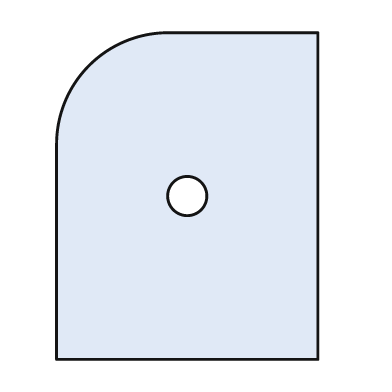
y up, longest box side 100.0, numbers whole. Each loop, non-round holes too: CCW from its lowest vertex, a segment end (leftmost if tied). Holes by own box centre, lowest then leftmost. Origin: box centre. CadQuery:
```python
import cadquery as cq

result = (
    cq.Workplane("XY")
    .moveTo(-40.0, -50.0)
    .lineTo(40.0, -50.0)
    .lineTo(40.0, 50.0)
    .lineTo(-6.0, 50.0)
    .threePointArc((-30.0, 40.0), (-40.0, 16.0))
    .close()
    .moveTo(0.0, 0.0)
    .circle(6.0)
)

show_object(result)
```